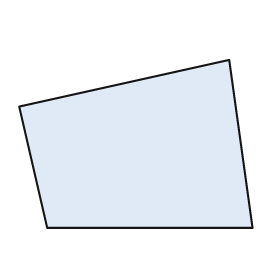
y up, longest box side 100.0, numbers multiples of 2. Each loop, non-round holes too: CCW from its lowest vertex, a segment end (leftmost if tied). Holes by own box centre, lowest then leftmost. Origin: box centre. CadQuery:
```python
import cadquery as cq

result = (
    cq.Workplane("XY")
    .moveTo(-38.0, -36.0)
    .lineTo(50.0, -36.0)
    .lineTo(40.0, 36.0)
    .lineTo(-50.0, 16.0)
    .close()
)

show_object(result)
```